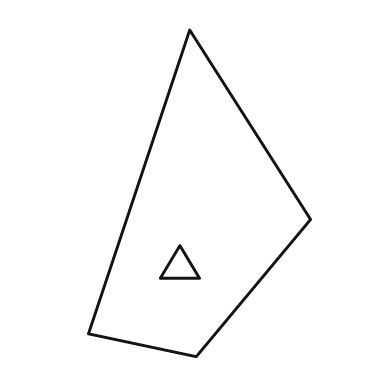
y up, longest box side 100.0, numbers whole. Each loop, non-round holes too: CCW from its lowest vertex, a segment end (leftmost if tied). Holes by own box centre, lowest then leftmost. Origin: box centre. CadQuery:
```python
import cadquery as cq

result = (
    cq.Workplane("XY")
    .moveTo(-1.0, -50.0)
    .lineTo(34.0, -8.0)
    .lineTo(-3.0, 50.0)
    .lineTo(-34.0, -43.0)
    .close()
    .moveTo(-12.0, -26.0)
    .lineTo(0.0, -26.0)
    .lineTo(-6.0, -16.0)
    .close()
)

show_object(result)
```